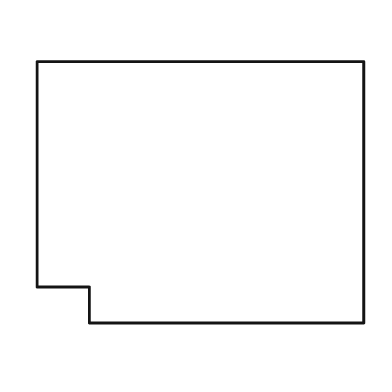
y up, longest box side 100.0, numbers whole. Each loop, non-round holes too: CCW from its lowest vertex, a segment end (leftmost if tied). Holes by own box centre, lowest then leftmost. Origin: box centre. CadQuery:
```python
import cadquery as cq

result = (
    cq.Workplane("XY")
    .moveTo(-34.0, -40.0)
    .lineTo(50.0, -40.0)
    .lineTo(50.0, 40.0)
    .lineTo(-50.0, 40.0)
    .lineTo(-50.0, -29.0)
    .lineTo(-34.0, -29.0)
    .close()
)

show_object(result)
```